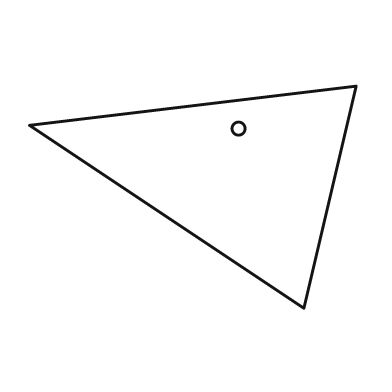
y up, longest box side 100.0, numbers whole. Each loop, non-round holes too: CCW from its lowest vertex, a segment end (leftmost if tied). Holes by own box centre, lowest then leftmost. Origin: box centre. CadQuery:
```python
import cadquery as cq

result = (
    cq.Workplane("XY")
    .moveTo(34.0, -34.0)
    .lineTo(50.0, 34.0)
    .lineTo(-50.0, 22.0)
    .close()
    .moveTo(14.0, 21.0)
    .circle(2.0)
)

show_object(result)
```